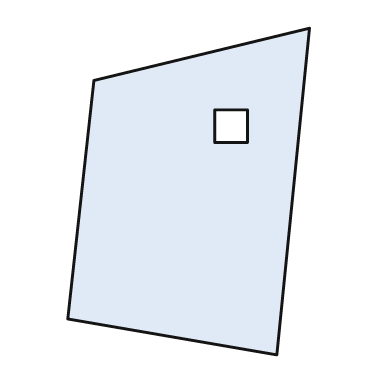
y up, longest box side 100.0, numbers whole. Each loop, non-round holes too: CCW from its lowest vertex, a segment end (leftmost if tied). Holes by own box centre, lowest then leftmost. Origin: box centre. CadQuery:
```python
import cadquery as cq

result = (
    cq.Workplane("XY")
    .moveTo(27.0, -50.0)
    .lineTo(37.0, 50.0)
    .lineTo(-29.0, 34.0)
    .lineTo(-37.0, -39.0)
    .close()
    .moveTo(8.0, 15.0)
    .lineTo(18.0, 15.0)
    .lineTo(18.0, 25.0)
    .lineTo(8.0, 25.0)
    .close()
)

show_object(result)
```